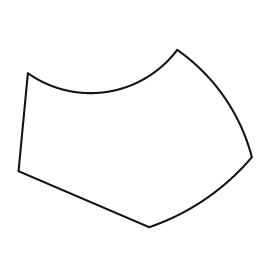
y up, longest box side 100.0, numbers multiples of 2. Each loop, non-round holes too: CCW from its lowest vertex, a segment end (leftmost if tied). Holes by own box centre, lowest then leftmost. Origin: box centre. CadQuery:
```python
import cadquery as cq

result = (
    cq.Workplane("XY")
    .moveTo(6.0, -38.0)
    .threePointArc((30.0, -26.0), (50.0, -8.0))
    .threePointArc((38.0, 18.0), (18.0, 38.0))
    .threePointArc((-12.0, 20.0), (-46.0, 28.0))
    .lineTo(-50.0, -14.0)
    .close()
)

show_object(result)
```